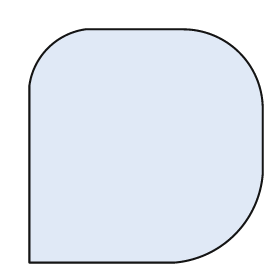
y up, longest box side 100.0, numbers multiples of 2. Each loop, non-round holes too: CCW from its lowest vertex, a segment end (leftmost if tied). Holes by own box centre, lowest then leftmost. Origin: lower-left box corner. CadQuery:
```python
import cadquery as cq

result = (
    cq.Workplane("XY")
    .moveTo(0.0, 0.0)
    .lineTo(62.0, 0.0)
    .threePointArc((88.0, 12.0), (100.0, 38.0))
    .lineTo(100.0, 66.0)
    .threePointArc((90.0, 90.0), (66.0, 100.0))
    .lineTo(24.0, 100.0)
    .threePointArc((8.0, 92.0), (0.0, 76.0))
    .close()
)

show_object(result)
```